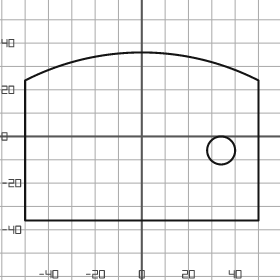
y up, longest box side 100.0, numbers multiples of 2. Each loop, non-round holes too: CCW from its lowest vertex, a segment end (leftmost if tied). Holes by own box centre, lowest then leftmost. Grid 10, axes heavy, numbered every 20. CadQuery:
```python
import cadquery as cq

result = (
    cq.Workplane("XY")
    .moveTo(-50.0, -36.0)
    .lineTo(50.0, -36.0)
    .lineTo(50.0, 24.0)
    .threePointArc((0.0, 36.0), (-50.0, 24.0))
    .close()
    .moveTo(34.0, -6.0)
    .circle(6.0)
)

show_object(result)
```